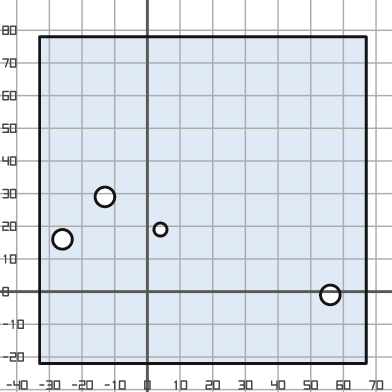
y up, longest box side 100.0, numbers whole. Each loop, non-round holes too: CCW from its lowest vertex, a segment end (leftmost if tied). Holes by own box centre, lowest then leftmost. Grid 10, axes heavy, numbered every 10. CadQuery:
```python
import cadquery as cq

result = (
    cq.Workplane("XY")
    .moveTo(-33.0, -22.0)
    .lineTo(67.0, -22.0)
    .lineTo(67.0, 78.0)
    .lineTo(-33.0, 78.0)
    .close()
    .moveTo(56.0, -1.0)
    .circle(3.0)
    .moveTo(-26.0, 16.0)
    .circle(3.0)
    .moveTo(4.0, 19.0)
    .circle(2.0)
    .moveTo(-13.0, 29.0)
    .circle(3.0)
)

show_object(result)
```